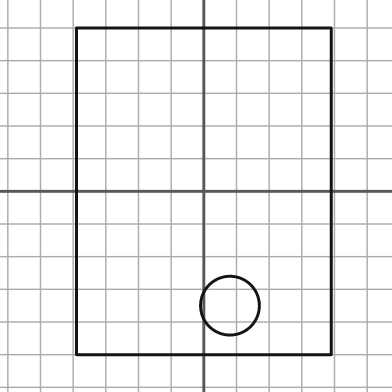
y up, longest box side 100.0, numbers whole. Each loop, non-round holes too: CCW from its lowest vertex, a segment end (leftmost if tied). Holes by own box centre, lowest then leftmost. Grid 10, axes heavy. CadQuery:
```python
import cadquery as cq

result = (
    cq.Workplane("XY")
    .moveTo(-39.0, -50.0)
    .lineTo(39.0, -50.0)
    .lineTo(39.0, 50.0)
    .lineTo(-39.0, 50.0)
    .close()
    .moveTo(8.0, -35.0)
    .circle(9.0)
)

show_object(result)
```